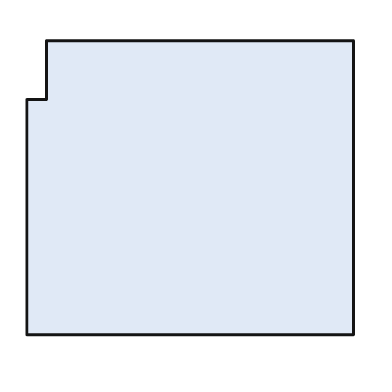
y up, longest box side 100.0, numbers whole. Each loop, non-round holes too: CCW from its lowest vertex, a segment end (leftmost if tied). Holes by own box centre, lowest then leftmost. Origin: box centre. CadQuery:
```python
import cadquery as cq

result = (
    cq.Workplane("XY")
    .moveTo(-50.0, -45.0)
    .lineTo(50.0, -45.0)
    .lineTo(50.0, 45.0)
    .lineTo(-44.0, 45.0)
    .lineTo(-44.0, 27.0)
    .lineTo(-50.0, 27.0)
    .close()
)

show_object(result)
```